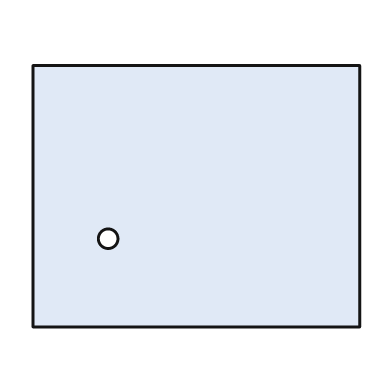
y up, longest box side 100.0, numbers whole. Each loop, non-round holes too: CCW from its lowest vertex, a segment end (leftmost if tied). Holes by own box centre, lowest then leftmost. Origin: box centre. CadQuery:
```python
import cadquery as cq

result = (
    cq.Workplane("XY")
    .moveTo(-50.0, -40.0)
    .lineTo(50.0, -40.0)
    .lineTo(50.0, 40.0)
    .lineTo(-50.0, 40.0)
    .close()
    .moveTo(-27.0, -13.0)
    .circle(3.0)
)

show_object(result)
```